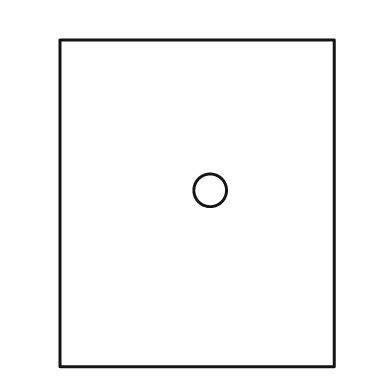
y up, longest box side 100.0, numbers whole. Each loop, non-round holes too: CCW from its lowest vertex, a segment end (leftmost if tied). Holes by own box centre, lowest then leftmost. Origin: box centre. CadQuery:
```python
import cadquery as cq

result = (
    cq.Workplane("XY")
    .moveTo(-42.0, -50.0)
    .lineTo(42.0, -50.0)
    .lineTo(42.0, 50.0)
    .lineTo(-42.0, 50.0)
    .close()
    .moveTo(4.0, 4.0)
    .circle(5.0)
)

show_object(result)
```